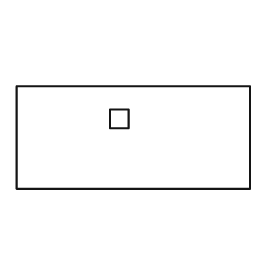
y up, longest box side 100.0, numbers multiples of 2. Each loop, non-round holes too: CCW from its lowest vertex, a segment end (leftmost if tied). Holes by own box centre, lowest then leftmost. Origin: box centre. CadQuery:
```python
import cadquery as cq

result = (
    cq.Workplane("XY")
    .moveTo(-50.0, -22.0)
    .lineTo(50.0, -22.0)
    .lineTo(50.0, 22.0)
    .lineTo(-50.0, 22.0)
    .close()
    .moveTo(-10.0, 4.0)
    .lineTo(-2.0, 4.0)
    .lineTo(-2.0, 12.0)
    .lineTo(-10.0, 12.0)
    .close()
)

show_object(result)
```